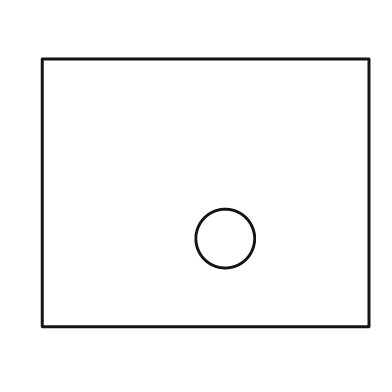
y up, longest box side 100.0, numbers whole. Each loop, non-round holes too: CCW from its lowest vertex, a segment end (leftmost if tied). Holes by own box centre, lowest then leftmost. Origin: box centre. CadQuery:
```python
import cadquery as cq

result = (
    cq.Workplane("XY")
    .moveTo(-50.0, -41.0)
    .lineTo(50.0, -41.0)
    .lineTo(50.0, 41.0)
    .lineTo(-50.0, 41.0)
    .close()
    .moveTo(6.0, -14.0)
    .circle(9.0)
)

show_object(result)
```